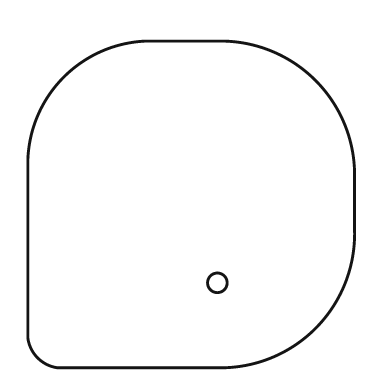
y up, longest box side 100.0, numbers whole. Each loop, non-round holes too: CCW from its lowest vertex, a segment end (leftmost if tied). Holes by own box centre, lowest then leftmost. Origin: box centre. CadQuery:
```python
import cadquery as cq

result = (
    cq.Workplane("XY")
    .moveTo(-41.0, -50.0)
    .lineTo(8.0, -50.0)
    .threePointArc((38.0, -38.0), (50.0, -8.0))
    .lineTo(50.0, 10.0)
    .threePointArc((38.0, 38.0), (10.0, 50.0))
    .lineTo(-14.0, 50.0)
    .threePointArc((-39.0, 39.0), (-50.0, 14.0))
    .lineTo(-50.0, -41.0)
    .threePointArc((-47.0, -47.0), (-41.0, -50.0))
    .close()
    .moveTo(8.0, -24.0)
    .circle(3.0)
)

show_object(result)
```